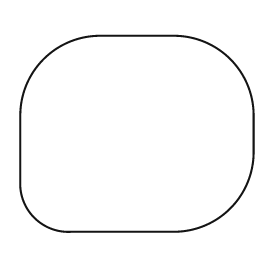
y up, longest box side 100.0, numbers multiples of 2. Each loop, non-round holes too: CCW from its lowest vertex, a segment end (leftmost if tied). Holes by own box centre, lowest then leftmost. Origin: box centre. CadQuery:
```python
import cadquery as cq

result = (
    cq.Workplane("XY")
    .moveTo(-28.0, -42.0)
    .lineTo(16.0, -42.0)
    .threePointArc((40.0, -32.0), (50.0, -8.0))
    .lineTo(50.0, 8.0)
    .threePointArc((40.0, 32.0), (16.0, 42.0))
    .lineTo(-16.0, 42.0)
    .threePointArc((-40.0, 32.0), (-50.0, 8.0))
    .lineTo(-50.0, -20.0)
    .threePointArc((-44.0, -36.0), (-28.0, -42.0))
    .close()
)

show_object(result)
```